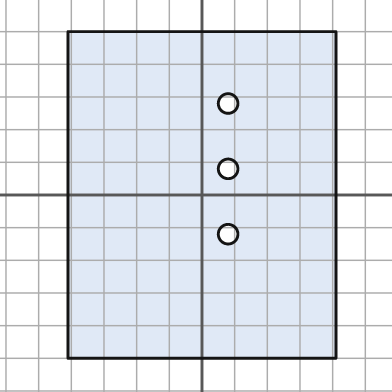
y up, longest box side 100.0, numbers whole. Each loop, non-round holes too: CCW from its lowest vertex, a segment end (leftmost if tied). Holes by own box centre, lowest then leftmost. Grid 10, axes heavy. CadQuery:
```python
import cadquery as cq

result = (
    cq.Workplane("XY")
    .moveTo(-41.0, -50.0)
    .lineTo(41.0, -50.0)
    .lineTo(41.0, 50.0)
    .lineTo(-41.0, 50.0)
    .close()
    .moveTo(8.0, -12.0)
    .circle(3.0)
    .moveTo(8.0, 8.0)
    .circle(3.0)
    .moveTo(8.0, 28.0)
    .circle(3.0)
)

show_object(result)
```